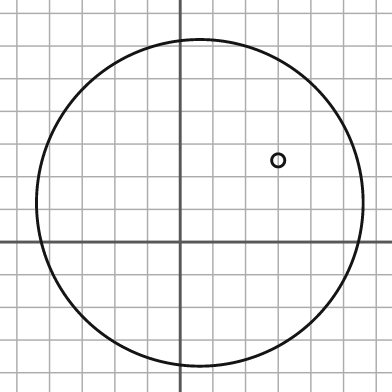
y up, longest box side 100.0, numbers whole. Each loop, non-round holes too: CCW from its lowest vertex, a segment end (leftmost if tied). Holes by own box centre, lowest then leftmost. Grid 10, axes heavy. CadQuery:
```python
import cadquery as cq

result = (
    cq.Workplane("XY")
    .moveTo(6.0, 12.0)
    .circle(50.0)
    .moveTo(30.0, 25.0)
    .circle(2.0)
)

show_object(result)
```